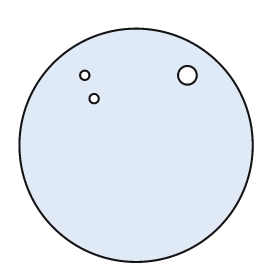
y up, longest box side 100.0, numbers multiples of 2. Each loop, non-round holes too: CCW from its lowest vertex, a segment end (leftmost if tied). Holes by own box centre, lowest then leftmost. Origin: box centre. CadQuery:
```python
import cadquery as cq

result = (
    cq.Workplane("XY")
    .moveTo(0.0, 0.0)
    .circle(50.0)
    .moveTo(-18.0, 20.0)
    .circle(2.0)
    .moveTo(-22.0, 30.0)
    .circle(2.0)
    .moveTo(22.0, 30.0)
    .circle(4.0)
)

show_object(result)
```